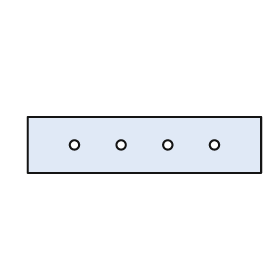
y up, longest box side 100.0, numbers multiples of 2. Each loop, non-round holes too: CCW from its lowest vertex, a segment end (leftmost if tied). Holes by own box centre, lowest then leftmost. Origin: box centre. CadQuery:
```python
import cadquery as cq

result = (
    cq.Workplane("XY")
    .moveTo(-50.0, -12.0)
    .lineTo(50.0, -12.0)
    .lineTo(50.0, 12.0)
    .lineTo(-50.0, 12.0)
    .close()
    .moveTo(-30.0, 0.0)
    .circle(2.0)
    .moveTo(-10.0, 0.0)
    .circle(2.0)
    .moveTo(10.0, 0.0)
    .circle(2.0)
    .moveTo(30.0, 0.0)
    .circle(2.0)
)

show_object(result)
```